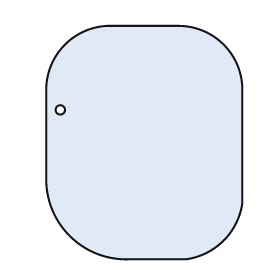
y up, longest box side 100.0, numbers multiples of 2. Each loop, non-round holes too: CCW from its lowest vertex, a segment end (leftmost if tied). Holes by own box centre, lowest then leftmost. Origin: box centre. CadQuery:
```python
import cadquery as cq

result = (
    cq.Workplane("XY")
    .moveTo(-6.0, -50.0)
    .lineTo(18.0, -50.0)
    .threePointArc((34.0, -42.0), (42.0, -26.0))
    .lineTo(42.0, 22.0)
    .threePointArc((34.0, 42.0), (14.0, 50.0))
    .lineTo(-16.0, 50.0)
    .threePointArc((-34.0, 42.0), (-42.0, 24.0))
    .lineTo(-42.0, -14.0)
    .threePointArc((-32.0, -40.0), (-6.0, -50.0))
    .close()
    .moveTo(-36.0, 14.0)
    .circle(2.0)
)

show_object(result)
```